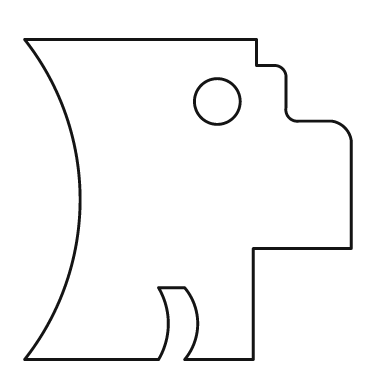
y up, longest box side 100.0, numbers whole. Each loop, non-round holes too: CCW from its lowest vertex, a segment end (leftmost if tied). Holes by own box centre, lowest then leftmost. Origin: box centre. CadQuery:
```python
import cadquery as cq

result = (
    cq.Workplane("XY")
    .moveTo(-50.0, -49.0)
    .lineTo(-9.0, -49.0)
    .threePointArc((-6.0, -38.0), (-9.0, -27.0))
    .lineTo(-1.0, -27.0)
    .threePointArc((3.0, -38.0), (-1.0, -49.0))
    .lineTo(20.0, -49.0)
    .lineTo(20.0, -15.0)
    .lineTo(50.0, -15.0)
    .lineTo(50.0, 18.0)
    .threePointArc((48.0, 22.0), (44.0, 24.0))
    .lineTo(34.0, 24.0)
    .threePointArc((31.0, 25.0), (30.0, 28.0))
    .lineTo(30.0, 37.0)
    .threePointArc((29.0, 40.0), (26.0, 41.0))
    .lineTo(21.0, 41.0)
    .lineTo(21.0, 49.0)
    .lineTo(-50.0, 49.0)
    .threePointArc((-33.0, 0.0), (-50.0, -49.0))
    .close()
    .moveTo(9.0, 30.0)
    .circle(7.0)
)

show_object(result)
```